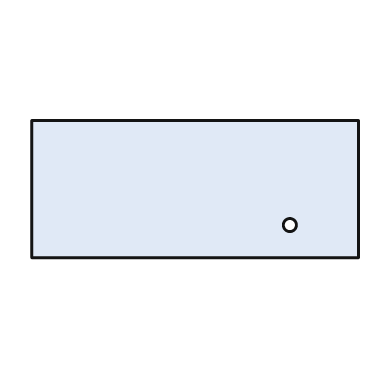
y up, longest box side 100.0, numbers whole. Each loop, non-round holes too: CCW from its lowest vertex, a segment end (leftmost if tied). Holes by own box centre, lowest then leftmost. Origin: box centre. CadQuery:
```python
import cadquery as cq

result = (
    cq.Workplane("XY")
    .moveTo(-50.0, -21.0)
    .lineTo(50.0, -21.0)
    .lineTo(50.0, 21.0)
    .lineTo(-50.0, 21.0)
    .close()
    .moveTo(29.0, -11.0)
    .circle(2.0)
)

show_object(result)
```